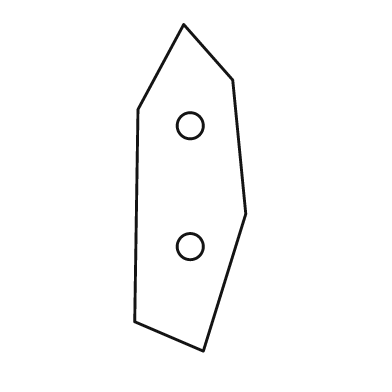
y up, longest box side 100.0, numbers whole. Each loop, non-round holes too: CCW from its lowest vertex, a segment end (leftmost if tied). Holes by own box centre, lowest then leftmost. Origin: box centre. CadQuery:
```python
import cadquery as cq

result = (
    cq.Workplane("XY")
    .moveTo(4.0, -50.0)
    .lineTo(17.0, -8.0)
    .lineTo(13.0, 33.0)
    .lineTo(-2.0, 50.0)
    .lineTo(-16.0, 24.0)
    .lineTo(-17.0, -41.0)
    .close()
    .moveTo(0.0, -18.0)
    .circle(4.0)
    .moveTo(0.0, 19.0)
    .circle(4.0)
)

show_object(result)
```